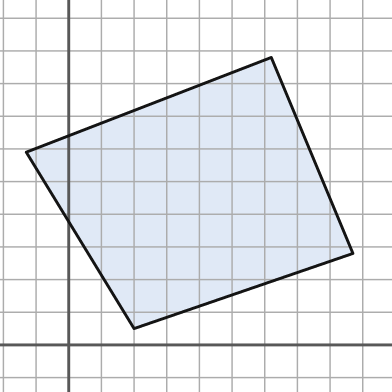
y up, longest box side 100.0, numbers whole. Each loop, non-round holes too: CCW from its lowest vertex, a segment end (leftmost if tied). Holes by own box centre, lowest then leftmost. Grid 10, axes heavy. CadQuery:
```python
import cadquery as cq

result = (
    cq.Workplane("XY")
    .moveTo(20.0, 5.0)
    .lineTo(87.0, 28.0)
    .lineTo(62.0, 88.0)
    .lineTo(-13.0, 59.0)
    .close()
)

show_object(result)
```